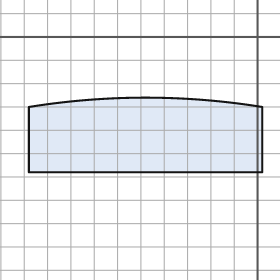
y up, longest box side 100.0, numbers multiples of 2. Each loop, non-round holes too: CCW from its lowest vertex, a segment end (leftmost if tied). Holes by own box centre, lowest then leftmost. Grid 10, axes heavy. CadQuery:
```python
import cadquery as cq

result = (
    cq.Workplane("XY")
    .moveTo(-98.0, -58.0)
    .lineTo(2.0, -58.0)
    .lineTo(2.0, -30.0)
    .threePointArc((-48.0, -26.0), (-98.0, -30.0))
    .close()
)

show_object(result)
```